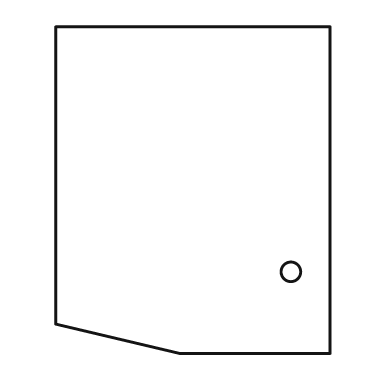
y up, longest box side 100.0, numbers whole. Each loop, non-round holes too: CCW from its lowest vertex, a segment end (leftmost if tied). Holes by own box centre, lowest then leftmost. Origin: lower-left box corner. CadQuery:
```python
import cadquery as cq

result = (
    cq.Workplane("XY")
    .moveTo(38.0, 0.0)
    .lineTo(84.0, 0.0)
    .lineTo(84.0, 100.0)
    .lineTo(0.0, 100.0)
    .lineTo(0.0, 9.0)
    .close()
    .moveTo(72.0, 25.0)
    .circle(3.0)
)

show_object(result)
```